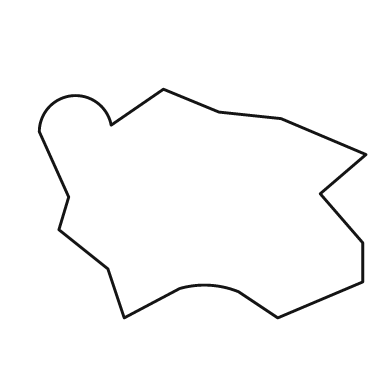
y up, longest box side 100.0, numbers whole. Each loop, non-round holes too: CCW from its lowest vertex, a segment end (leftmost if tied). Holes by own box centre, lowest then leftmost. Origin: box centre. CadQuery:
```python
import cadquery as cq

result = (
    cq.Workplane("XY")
    .moveTo(-24.0, -35.0)
    .lineTo(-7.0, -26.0)
    .threePointArc((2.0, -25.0), (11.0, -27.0))
    .lineTo(23.0, -35.0)
    .lineTo(49.0, -24.0)
    .lineTo(49.0, -12.0)
    .lineTo(36.0, 3.0)
    .lineTo(50.0, 15.0)
    .lineTo(24.0, 26.0)
    .lineTo(5.0, 28.0)
    .lineTo(-12.0, 35.0)
    .lineTo(-28.0, 24.0)
    .threePointArc((-40.0, 33.0), (-50.0, 22.0))
    .lineTo(-41.0, 2.0)
    .lineTo(-44.0, -8.0)
    .lineTo(-29.0, -20.0)
    .close()
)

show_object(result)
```